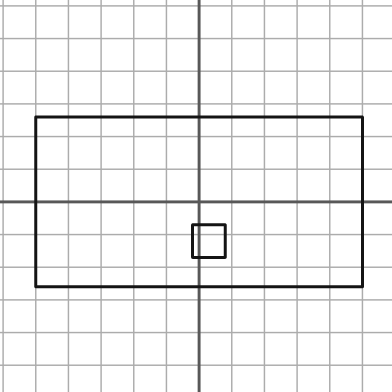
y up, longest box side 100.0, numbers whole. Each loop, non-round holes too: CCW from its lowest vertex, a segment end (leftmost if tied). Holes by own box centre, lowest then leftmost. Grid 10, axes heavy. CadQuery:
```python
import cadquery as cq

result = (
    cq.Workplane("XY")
    .moveTo(-50.0, -26.0)
    .lineTo(50.0, -26.0)
    .lineTo(50.0, 26.0)
    .lineTo(-50.0, 26.0)
    .close()
    .moveTo(-2.0, -17.0)
    .lineTo(8.0, -17.0)
    .lineTo(8.0, -7.0)
    .lineTo(-2.0, -7.0)
    .close()
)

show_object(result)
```